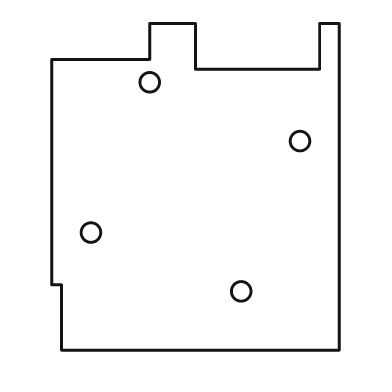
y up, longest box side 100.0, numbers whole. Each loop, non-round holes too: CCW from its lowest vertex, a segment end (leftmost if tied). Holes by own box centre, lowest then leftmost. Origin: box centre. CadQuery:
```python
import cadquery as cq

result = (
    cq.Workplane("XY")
    .moveTo(-41.0, -50.0)
    .lineTo(44.0, -50.0)
    .lineTo(44.0, 50.0)
    .lineTo(38.0, 50.0)
    .lineTo(38.0, 36.0)
    .lineTo(0.0, 36.0)
    .lineTo(0.0, 50.0)
    .lineTo(-14.0, 50.0)
    .lineTo(-14.0, 39.0)
    .lineTo(-44.0, 39.0)
    .lineTo(-44.0, -30.0)
    .lineTo(-41.0, -30.0)
    .close()
    .moveTo(14.0, -32.0)
    .circle(3.0)
    .moveTo(-32.0, -14.0)
    .circle(3.0)
    .moveTo(32.0, 14.0)
    .circle(3.0)
    .moveTo(-14.0, 32.0)
    .circle(3.0)
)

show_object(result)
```